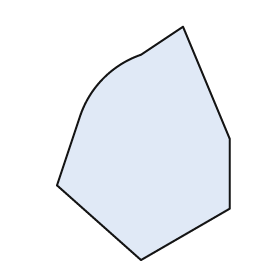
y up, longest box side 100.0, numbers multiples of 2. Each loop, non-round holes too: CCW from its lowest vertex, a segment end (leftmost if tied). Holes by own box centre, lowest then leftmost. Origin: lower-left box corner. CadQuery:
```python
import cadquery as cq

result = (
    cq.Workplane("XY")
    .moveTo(36.0, 0.0)
    .lineTo(74.0, 22.0)
    .lineTo(74.0, 52.0)
    .lineTo(54.0, 100.0)
    .lineTo(36.0, 88.0)
    .threePointArc((20.0, 78.0), (10.0, 62.0))
    .lineTo(0.0, 32.0)
    .close()
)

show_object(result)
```